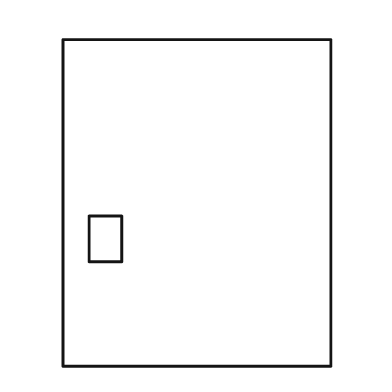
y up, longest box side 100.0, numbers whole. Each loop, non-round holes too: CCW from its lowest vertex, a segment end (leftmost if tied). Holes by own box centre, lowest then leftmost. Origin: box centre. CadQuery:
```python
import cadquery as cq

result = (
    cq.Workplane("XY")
    .moveTo(-41.0, -50.0)
    .lineTo(41.0, -50.0)
    .lineTo(41.0, 50.0)
    .lineTo(-41.0, 50.0)
    .close()
    .moveTo(-33.0, -18.0)
    .lineTo(-23.0, -18.0)
    .lineTo(-23.0, -4.0)
    .lineTo(-33.0, -4.0)
    .close()
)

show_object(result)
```